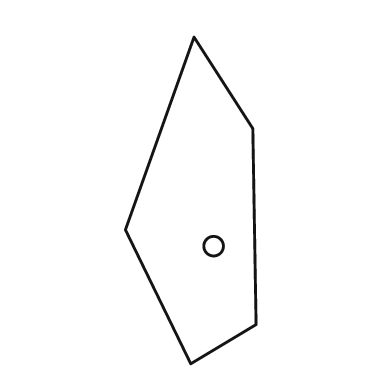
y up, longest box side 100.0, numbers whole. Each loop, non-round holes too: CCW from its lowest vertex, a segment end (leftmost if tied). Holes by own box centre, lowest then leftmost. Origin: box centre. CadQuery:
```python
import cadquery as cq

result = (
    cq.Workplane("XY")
    .moveTo(0.0, -50.0)
    .lineTo(20.0, -38.0)
    .lineTo(19.0, 22.0)
    .lineTo(1.0, 50.0)
    .lineTo(-20.0, -9.0)
    .close()
    .moveTo(7.0, -14.0)
    .circle(3.0)
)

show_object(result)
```